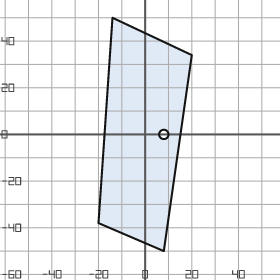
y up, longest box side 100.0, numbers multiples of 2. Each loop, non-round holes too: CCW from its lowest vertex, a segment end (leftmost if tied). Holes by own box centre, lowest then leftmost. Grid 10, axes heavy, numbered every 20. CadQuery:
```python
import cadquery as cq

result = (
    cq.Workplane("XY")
    .moveTo(8.0, -50.0)
    .lineTo(20.0, 34.0)
    .lineTo(-14.0, 50.0)
    .lineTo(-20.0, -38.0)
    .close()
    .moveTo(8.0, 0.0)
    .circle(2.0)
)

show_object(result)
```